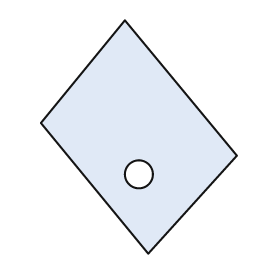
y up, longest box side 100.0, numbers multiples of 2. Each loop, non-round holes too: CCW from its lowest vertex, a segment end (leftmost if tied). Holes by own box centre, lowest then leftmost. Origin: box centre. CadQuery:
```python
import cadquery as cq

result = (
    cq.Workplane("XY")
    .moveTo(4.0, -50.0)
    .lineTo(42.0, -8.0)
    .lineTo(-6.0, 50.0)
    .lineTo(-42.0, 6.0)
    .close()
    .moveTo(0.0, -16.0)
    .circle(6.0)
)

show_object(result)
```